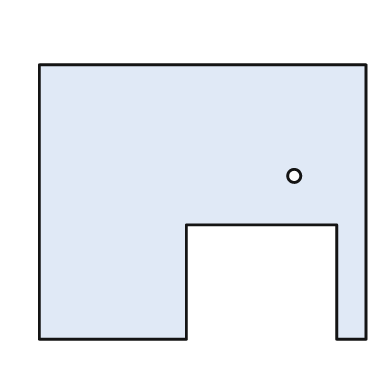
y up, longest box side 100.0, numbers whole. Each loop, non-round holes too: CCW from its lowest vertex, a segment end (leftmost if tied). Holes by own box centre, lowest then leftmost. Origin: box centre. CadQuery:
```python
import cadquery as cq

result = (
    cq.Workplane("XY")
    .moveTo(-50.0, -42.0)
    .lineTo(-5.0, -42.0)
    .lineTo(-5.0, -7.0)
    .lineTo(41.0, -7.0)
    .lineTo(41.0, -42.0)
    .lineTo(50.0, -42.0)
    .lineTo(50.0, 42.0)
    .lineTo(-50.0, 42.0)
    .close()
    .moveTo(28.0, 8.0)
    .circle(2.0)
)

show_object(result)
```